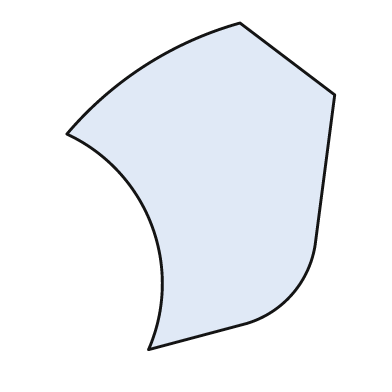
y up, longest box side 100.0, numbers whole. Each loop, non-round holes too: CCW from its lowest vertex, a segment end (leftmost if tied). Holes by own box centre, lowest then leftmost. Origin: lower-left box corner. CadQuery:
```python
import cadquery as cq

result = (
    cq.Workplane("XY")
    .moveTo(25.0, 0.0)
    .lineTo(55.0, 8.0)
    .threePointArc((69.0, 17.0), (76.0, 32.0))
    .lineTo(82.0, 78.0)
    .lineTo(53.0, 100.0)
    .threePointArc((24.0, 87.0), (0.0, 66.0))
    .threePointArc((26.0, 38.0), (25.0, 0.0))
    .close()
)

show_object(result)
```